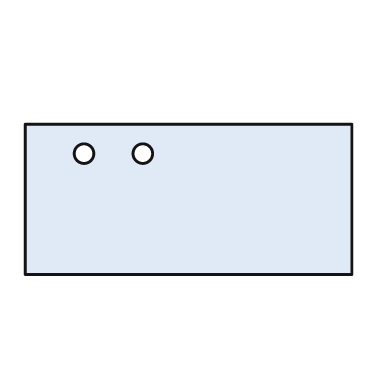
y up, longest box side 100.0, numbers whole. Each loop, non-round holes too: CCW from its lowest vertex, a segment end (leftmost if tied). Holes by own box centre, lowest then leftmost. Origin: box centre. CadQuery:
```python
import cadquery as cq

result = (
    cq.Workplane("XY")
    .moveTo(-50.0, -23.0)
    .lineTo(50.0, -23.0)
    .lineTo(50.0, 23.0)
    .lineTo(-50.0, 23.0)
    .close()
    .moveTo(-32.0, 14.0)
    .circle(3.0)
    .moveTo(-14.0, 14.0)
    .circle(3.0)
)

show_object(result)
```